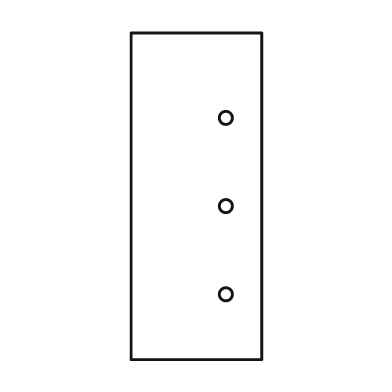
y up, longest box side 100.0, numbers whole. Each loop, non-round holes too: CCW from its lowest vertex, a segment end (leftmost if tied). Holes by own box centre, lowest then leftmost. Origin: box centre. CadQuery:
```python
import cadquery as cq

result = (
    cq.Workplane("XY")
    .moveTo(-20.0, -50.0)
    .lineTo(20.0, -50.0)
    .lineTo(20.0, 50.0)
    .lineTo(-20.0, 50.0)
    .close()
    .moveTo(9.0, -30.0)
    .circle(2.0)
    .moveTo(9.0, -3.0)
    .circle(2.0)
    .moveTo(9.0, 24.0)
    .circle(2.0)
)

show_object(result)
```